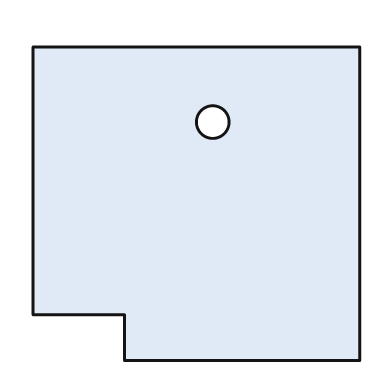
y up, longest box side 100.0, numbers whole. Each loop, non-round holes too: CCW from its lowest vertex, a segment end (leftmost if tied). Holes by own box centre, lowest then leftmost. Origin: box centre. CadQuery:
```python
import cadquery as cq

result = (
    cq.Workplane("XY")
    .moveTo(-22.0, -48.0)
    .lineTo(50.0, -48.0)
    .lineTo(50.0, 48.0)
    .lineTo(-50.0, 48.0)
    .lineTo(-50.0, -34.0)
    .lineTo(-22.0, -34.0)
    .close()
    .moveTo(5.0, 25.0)
    .circle(5.0)
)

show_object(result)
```